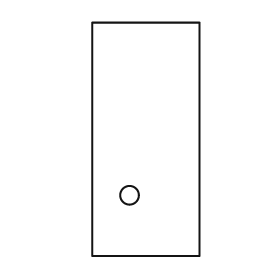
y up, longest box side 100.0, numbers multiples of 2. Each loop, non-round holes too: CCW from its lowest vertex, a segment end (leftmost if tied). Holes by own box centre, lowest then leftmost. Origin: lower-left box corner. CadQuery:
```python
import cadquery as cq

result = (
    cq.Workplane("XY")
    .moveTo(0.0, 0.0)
    .lineTo(46.0, 0.0)
    .lineTo(46.0, 100.0)
    .lineTo(0.0, 100.0)
    .close()
    .moveTo(16.0, 26.0)
    .circle(4.0)
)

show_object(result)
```